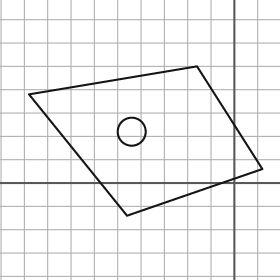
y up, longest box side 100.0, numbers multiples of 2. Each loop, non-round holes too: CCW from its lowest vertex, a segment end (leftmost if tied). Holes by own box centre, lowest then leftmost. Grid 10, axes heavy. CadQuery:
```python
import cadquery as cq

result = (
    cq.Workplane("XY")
    .moveTo(-46.0, -14.0)
    .lineTo(12.0, 6.0)
    .lineTo(-16.0, 50.0)
    .lineTo(-88.0, 38.0)
    .close()
    .moveTo(-44.0, 22.0)
    .circle(6.0)
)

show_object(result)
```